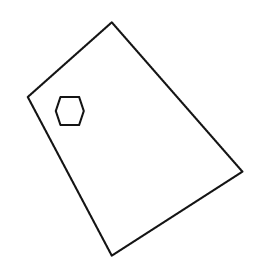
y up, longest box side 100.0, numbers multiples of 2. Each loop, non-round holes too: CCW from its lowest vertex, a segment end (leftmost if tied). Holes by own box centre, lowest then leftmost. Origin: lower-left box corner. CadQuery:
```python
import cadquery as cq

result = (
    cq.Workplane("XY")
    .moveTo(36.0, 0.0)
    .lineTo(92.0, 36.0)
    .lineTo(36.0, 100.0)
    .lineTo(0.0, 68.0)
    .close()
    .moveTo(14.0, 56.0)
    .lineTo(22.0, 56.0)
    .lineTo(24.0, 62.0)
    .lineTo(22.0, 68.0)
    .lineTo(14.0, 68.0)
    .lineTo(12.0, 62.0)
    .close()
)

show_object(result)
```